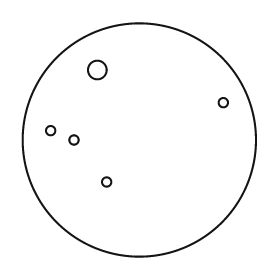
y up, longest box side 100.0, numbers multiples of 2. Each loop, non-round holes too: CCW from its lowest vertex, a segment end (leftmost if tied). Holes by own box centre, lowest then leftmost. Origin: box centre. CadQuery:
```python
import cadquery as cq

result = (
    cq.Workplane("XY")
    .moveTo(0.0, 0.0)
    .circle(50.0)
    .moveTo(-14.0, -18.0)
    .circle(2.0)
    .moveTo(-28.0, 0.0)
    .circle(2.0)
    .moveTo(-38.0, 4.0)
    .circle(2.0)
    .moveTo(36.0, 16.0)
    .circle(2.0)
    .moveTo(-18.0, 30.0)
    .circle(4.0)
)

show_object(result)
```